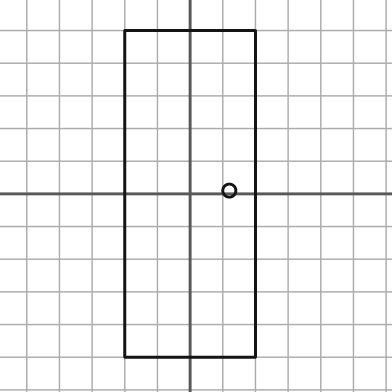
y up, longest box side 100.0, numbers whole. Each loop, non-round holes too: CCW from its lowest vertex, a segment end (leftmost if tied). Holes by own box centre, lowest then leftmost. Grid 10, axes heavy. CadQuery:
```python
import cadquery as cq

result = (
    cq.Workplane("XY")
    .moveTo(-20.0, -50.0)
    .lineTo(20.0, -50.0)
    .lineTo(20.0, 50.0)
    .lineTo(-20.0, 50.0)
    .close()
    .moveTo(12.0, 1.0)
    .circle(2.0)
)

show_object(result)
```